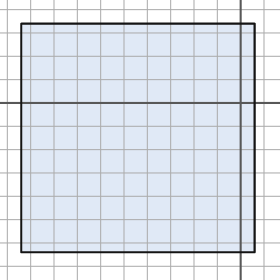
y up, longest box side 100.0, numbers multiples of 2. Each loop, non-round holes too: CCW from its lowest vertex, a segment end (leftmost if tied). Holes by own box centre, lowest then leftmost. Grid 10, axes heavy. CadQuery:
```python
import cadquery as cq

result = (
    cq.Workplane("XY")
    .moveTo(-94.0, -64.0)
    .lineTo(6.0, -64.0)
    .lineTo(6.0, 34.0)
    .lineTo(-94.0, 34.0)
    .close()
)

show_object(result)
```